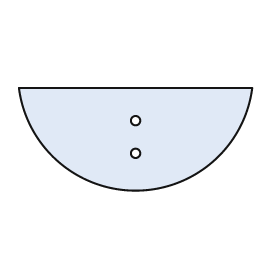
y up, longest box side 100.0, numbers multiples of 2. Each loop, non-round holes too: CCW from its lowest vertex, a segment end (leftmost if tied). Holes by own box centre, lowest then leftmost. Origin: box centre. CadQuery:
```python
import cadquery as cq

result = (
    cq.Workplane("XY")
    .moveTo(-50.0, 22.0)
    .threePointArc((0.0, -22.0), (50.0, 22.0))
    .close()
    .moveTo(0.0, -6.0)
    .circle(2.0)
    .moveTo(0.0, 8.0)
    .circle(2.0)
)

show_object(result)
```